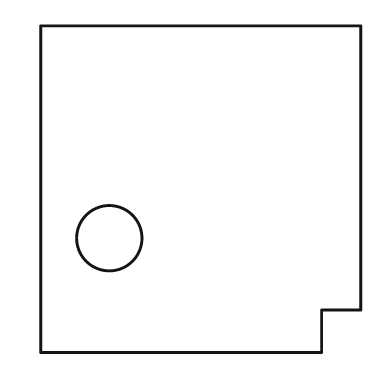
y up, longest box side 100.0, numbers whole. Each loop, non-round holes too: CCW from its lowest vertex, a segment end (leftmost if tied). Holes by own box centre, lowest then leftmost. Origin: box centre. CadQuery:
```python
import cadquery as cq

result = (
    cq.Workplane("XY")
    .moveTo(-49.0, -50.0)
    .lineTo(37.0, -50.0)
    .lineTo(37.0, -37.0)
    .lineTo(49.0, -37.0)
    .lineTo(49.0, 50.0)
    .lineTo(-49.0, 50.0)
    .close()
    .moveTo(-28.0, -15.0)
    .circle(10.0)
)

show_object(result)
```